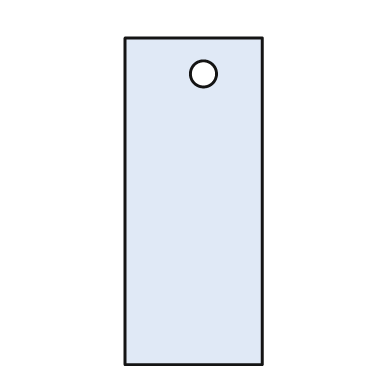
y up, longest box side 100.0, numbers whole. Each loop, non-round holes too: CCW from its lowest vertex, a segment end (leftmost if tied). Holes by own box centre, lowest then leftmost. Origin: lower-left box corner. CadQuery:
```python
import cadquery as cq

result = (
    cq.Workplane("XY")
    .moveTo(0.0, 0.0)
    .lineTo(42.0, 0.0)
    .lineTo(42.0, 100.0)
    .lineTo(0.0, 100.0)
    .close()
    .moveTo(24.0, 89.0)
    .circle(4.0)
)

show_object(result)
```